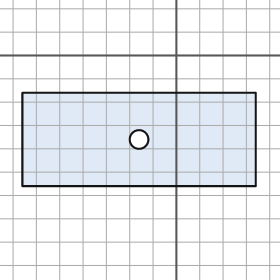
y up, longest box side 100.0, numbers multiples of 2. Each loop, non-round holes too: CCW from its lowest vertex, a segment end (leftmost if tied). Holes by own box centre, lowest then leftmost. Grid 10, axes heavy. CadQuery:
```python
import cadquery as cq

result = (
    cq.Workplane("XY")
    .moveTo(-66.0, -56.0)
    .lineTo(34.0, -56.0)
    .lineTo(34.0, -16.0)
    .lineTo(-66.0, -16.0)
    .close()
    .moveTo(-16.0, -36.0)
    .circle(4.0)
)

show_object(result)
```